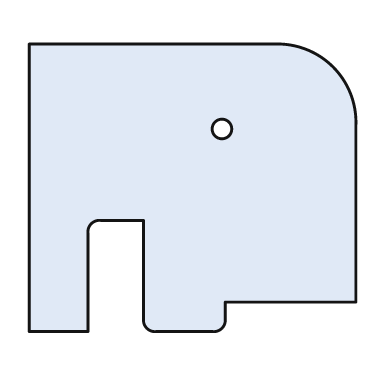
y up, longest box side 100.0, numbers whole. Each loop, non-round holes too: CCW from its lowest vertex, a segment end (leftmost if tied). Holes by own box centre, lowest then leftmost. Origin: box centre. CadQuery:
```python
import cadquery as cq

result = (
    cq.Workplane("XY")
    .moveTo(-50.0, -44.0)
    .lineTo(-32.0, -44.0)
    .lineTo(-32.0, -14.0)
    .threePointArc((-31.0, -11.0), (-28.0, -10.0))
    .lineTo(-15.0, -10.0)
    .lineTo(-15.0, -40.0)
    .threePointArc((-14.0, -43.0), (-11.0, -44.0))
    .lineTo(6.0, -44.0)
    .threePointArc((9.0, -43.0), (10.0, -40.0))
    .lineTo(10.0, -35.0)
    .lineTo(50.0, -35.0)
    .lineTo(50.0, 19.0)
    .threePointArc((43.0, 37.0), (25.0, 44.0))
    .lineTo(-50.0, 44.0)
    .close()
    .moveTo(9.0, 18.0)
    .circle(3.0)
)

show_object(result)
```